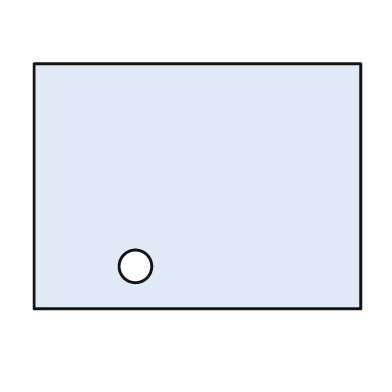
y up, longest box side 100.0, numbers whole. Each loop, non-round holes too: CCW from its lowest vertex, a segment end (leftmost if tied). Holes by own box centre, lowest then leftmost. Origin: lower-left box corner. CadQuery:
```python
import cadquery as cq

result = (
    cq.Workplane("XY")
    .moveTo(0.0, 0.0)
    .lineTo(100.0, 0.0)
    .lineTo(100.0, 75.0)
    .lineTo(0.0, 75.0)
    .close()
    .moveTo(31.0, 13.0)
    .circle(5.0)
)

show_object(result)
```